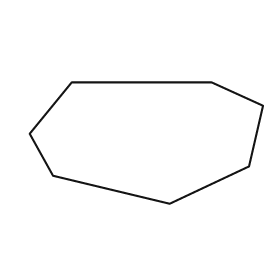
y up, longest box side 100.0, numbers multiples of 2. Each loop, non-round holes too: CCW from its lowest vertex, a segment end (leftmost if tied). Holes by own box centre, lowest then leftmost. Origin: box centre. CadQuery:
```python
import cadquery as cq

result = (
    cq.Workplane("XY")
    .moveTo(10.0, -26.0)
    .lineTo(44.0, -10.0)
    .lineTo(50.0, 16.0)
    .lineTo(28.0, 26.0)
    .lineTo(-32.0, 26.0)
    .lineTo(-50.0, 4.0)
    .lineTo(-40.0, -14.0)
    .close()
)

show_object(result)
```